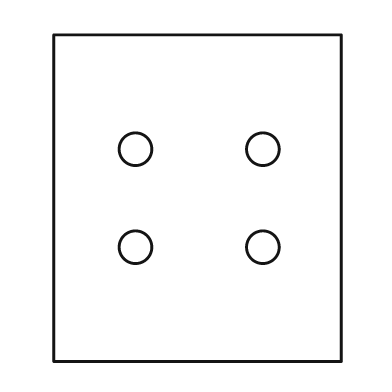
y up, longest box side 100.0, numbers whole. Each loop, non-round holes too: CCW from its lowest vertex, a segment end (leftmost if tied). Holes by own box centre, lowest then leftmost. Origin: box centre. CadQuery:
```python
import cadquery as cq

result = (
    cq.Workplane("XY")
    .moveTo(-44.0, -50.0)
    .lineTo(44.0, -50.0)
    .lineTo(44.0, 50.0)
    .lineTo(-44.0, 50.0)
    .close()
    .moveTo(-19.0, -15.0)
    .circle(5.0)
    .moveTo(20.0, -15.0)
    .circle(5.0)
    .moveTo(-19.0, 15.0)
    .circle(5.0)
    .moveTo(20.0, 15.0)
    .circle(5.0)
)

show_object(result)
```